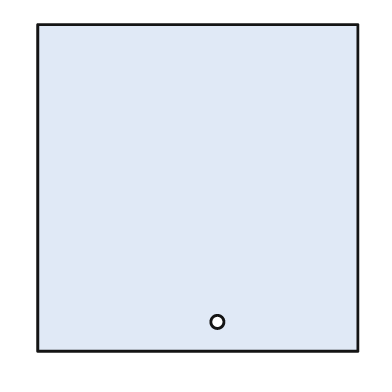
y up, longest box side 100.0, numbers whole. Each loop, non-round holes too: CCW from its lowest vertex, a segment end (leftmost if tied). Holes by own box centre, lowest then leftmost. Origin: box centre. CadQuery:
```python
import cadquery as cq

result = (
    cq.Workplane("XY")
    .moveTo(-49.0, -50.0)
    .lineTo(49.0, -50.0)
    .lineTo(49.0, 50.0)
    .lineTo(-49.0, 50.0)
    .close()
    .moveTo(6.0, -41.0)
    .circle(2.0)
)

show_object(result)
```